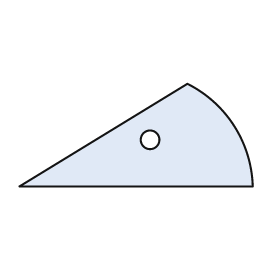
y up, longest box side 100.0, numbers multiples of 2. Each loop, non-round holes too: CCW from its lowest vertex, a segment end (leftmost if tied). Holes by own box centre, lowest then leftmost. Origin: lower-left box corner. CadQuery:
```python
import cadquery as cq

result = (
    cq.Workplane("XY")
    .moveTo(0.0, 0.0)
    .lineTo(100.0, 0.0)
    .threePointArc((92.0, 26.0), (72.0, 44.0))
    .close()
    .moveTo(56.0, 20.0)
    .circle(4.0)
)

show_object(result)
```